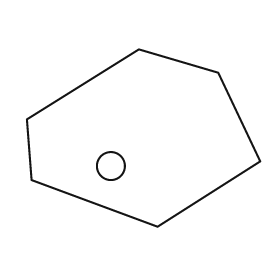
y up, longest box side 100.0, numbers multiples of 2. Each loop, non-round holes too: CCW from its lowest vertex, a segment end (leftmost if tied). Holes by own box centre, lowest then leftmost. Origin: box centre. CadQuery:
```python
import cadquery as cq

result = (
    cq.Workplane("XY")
    .moveTo(6.0, -38.0)
    .lineTo(50.0, -10.0)
    .lineTo(32.0, 28.0)
    .lineTo(-2.0, 38.0)
    .lineTo(-50.0, 8.0)
    .lineTo(-48.0, -18.0)
    .close()
    .moveTo(-14.0, -12.0)
    .circle(6.0)
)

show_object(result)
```